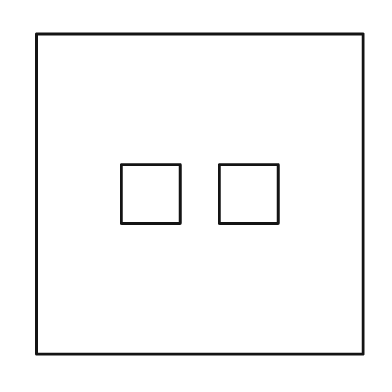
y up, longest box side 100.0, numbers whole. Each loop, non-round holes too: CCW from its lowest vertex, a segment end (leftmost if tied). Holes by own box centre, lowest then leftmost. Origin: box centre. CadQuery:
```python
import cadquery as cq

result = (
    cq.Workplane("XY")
    .moveTo(-50.0, -49.0)
    .lineTo(50.0, -49.0)
    .lineTo(50.0, 49.0)
    .lineTo(-50.0, 49.0)
    .close()
    .moveTo(-24.0, -9.0)
    .lineTo(-6.0, -9.0)
    .lineTo(-6.0, 9.0)
    .lineTo(-24.0, 9.0)
    .close()
    .moveTo(6.0, -9.0)
    .lineTo(24.0, -9.0)
    .lineTo(24.0, 9.0)
    .lineTo(6.0, 9.0)
    .close()
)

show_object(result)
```